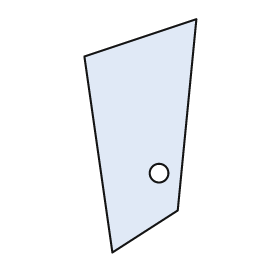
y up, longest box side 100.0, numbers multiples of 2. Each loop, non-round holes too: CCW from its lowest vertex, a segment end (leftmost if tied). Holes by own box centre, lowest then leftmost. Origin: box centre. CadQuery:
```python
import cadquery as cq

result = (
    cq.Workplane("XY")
    .moveTo(-12.0, -50.0)
    .lineTo(16.0, -32.0)
    .lineTo(24.0, 50.0)
    .lineTo(-24.0, 34.0)
    .close()
    .moveTo(8.0, -16.0)
    .circle(4.0)
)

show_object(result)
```